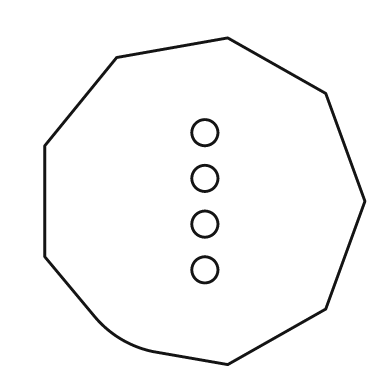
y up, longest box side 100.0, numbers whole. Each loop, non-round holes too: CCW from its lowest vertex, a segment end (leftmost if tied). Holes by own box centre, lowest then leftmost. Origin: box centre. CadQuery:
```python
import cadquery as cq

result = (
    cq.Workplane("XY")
    .moveTo(7.0, -50.0)
    .lineTo(37.0, -33.0)
    .lineTo(49.0, 0.0)
    .lineTo(37.0, 33.0)
    .lineTo(7.0, 50.0)
    .lineTo(-27.0, 44.0)
    .lineTo(-49.0, 17.0)
    .lineTo(-49.0, -17.0)
    .lineTo(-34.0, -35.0)
    .threePointArc((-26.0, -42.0), (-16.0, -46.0))
    .close()
    .moveTo(0.0, -21.0)
    .circle(4.0)
    .moveTo(0.0, -7.0)
    .circle(4.0)
    .moveTo(0.0, 7.0)
    .circle(4.0)
    .moveTo(0.0, 21.0)
    .circle(4.0)
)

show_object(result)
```